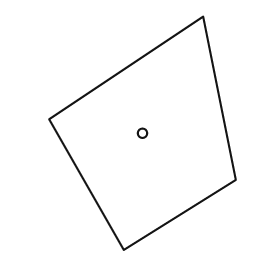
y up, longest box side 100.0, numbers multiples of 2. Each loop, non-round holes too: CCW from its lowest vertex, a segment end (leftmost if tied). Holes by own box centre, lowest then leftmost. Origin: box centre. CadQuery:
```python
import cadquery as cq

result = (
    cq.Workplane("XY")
    .moveTo(-8.0, -50.0)
    .lineTo(40.0, -20.0)
    .lineTo(26.0, 50.0)
    .lineTo(-40.0, 6.0)
    .close()
    .moveTo(0.0, 0.0)
    .circle(2.0)
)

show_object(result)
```